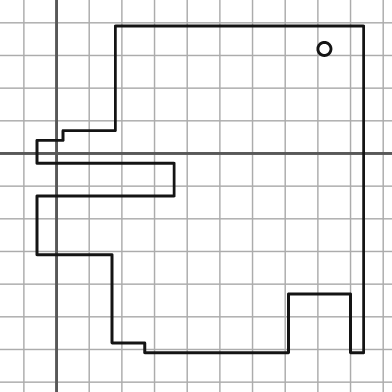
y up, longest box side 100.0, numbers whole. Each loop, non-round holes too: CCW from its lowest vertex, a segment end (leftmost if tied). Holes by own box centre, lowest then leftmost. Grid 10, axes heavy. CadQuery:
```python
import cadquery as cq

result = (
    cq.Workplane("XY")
    .moveTo(27.0, -61.0)
    .lineTo(71.0, -61.0)
    .lineTo(71.0, -43.0)
    .lineTo(90.0, -43.0)
    .lineTo(90.0, -61.0)
    .lineTo(94.0, -61.0)
    .lineTo(94.0, 39.0)
    .lineTo(18.0, 39.0)
    .lineTo(18.0, 7.0)
    .lineTo(2.0, 7.0)
    .lineTo(2.0, 4.0)
    .lineTo(-6.0, 4.0)
    .lineTo(-6.0, -3.0)
    .lineTo(36.0, -3.0)
    .lineTo(36.0, -13.0)
    .lineTo(-6.0, -13.0)
    .lineTo(-6.0, -31.0)
    .lineTo(17.0, -31.0)
    .lineTo(17.0, -58.0)
    .lineTo(27.0, -58.0)
    .close()
    .moveTo(82.0, 32.0)
    .circle(2.0)
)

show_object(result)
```